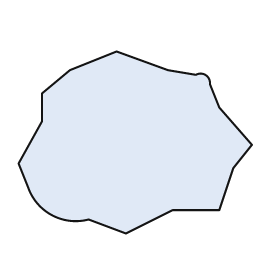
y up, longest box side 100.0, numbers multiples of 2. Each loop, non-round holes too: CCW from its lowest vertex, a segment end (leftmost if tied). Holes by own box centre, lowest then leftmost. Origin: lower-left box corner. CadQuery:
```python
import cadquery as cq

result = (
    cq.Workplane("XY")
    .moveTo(46.0, 0.0)
    .lineTo(66.0, 10.0)
    .lineTo(86.0, 10.0)
    .lineTo(92.0, 28.0)
    .lineTo(100.0, 38.0)
    .lineTo(86.0, 54.0)
    .lineTo(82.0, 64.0)
    .threePointArc((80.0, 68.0), (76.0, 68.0))
    .lineTo(64.0, 70.0)
    .lineTo(42.0, 78.0)
    .lineTo(22.0, 70.0)
    .lineTo(10.0, 60.0)
    .lineTo(10.0, 48.0)
    .lineTo(0.0, 30.0)
    .lineTo(4.0, 20.0)
    .threePointArc((14.0, 8.0), (30.0, 6.0))
    .close()
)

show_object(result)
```